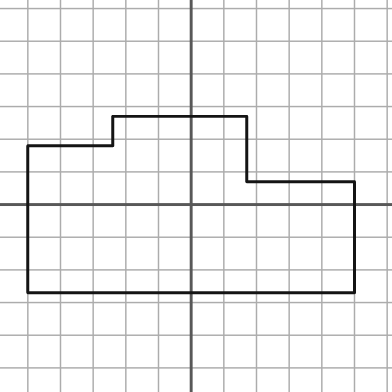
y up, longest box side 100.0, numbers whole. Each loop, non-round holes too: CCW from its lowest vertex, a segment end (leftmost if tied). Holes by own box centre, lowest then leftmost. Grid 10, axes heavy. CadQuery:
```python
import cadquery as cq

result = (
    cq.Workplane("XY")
    .moveTo(-50.0, -27.0)
    .lineTo(50.0, -27.0)
    .lineTo(50.0, 7.0)
    .lineTo(17.0, 7.0)
    .lineTo(17.0, 27.0)
    .lineTo(-24.0, 27.0)
    .lineTo(-24.0, 18.0)
    .lineTo(-50.0, 18.0)
    .close()
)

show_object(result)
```